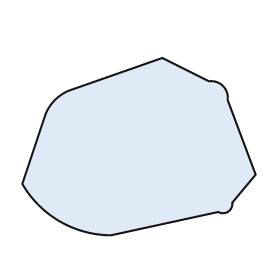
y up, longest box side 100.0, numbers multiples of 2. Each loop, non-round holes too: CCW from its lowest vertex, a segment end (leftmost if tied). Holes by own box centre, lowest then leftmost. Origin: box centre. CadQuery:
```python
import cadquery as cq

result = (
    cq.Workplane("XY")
    .moveTo(-12.0, -38.0)
    .lineTo(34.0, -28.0)
    .threePointArc((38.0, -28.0), (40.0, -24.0))
    .lineTo(50.0, -12.0)
    .lineTo(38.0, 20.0)
    .threePointArc((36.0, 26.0), (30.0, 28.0))
    .lineTo(10.0, 38.0)
    .lineTo(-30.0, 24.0)
    .threePointArc((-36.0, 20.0), (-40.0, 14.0))
    .lineTo(-50.0, -16.0)
    .threePointArc((-34.0, -32.0), (-12.0, -38.0))
    .close()
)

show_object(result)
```